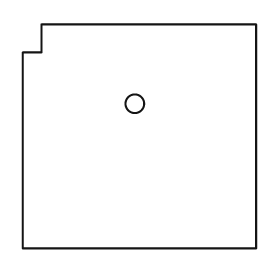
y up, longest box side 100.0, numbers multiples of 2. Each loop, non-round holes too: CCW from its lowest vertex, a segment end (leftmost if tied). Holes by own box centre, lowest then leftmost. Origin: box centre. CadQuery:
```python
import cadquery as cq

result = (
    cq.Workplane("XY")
    .moveTo(-50.0, -48.0)
    .lineTo(50.0, -48.0)
    .lineTo(50.0, 48.0)
    .lineTo(-42.0, 48.0)
    .lineTo(-42.0, 36.0)
    .lineTo(-50.0, 36.0)
    .close()
    .moveTo(-2.0, 14.0)
    .circle(4.0)
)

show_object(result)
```